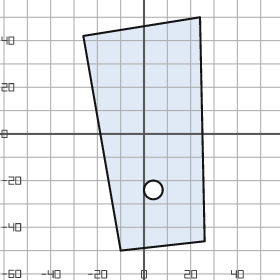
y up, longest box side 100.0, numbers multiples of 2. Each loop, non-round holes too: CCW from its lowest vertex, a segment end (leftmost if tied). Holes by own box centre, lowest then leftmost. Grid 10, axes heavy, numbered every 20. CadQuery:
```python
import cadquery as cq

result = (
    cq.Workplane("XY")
    .moveTo(-10.0, -50.0)
    .lineTo(26.0, -46.0)
    .lineTo(24.0, 50.0)
    .lineTo(-26.0, 42.0)
    .close()
    .moveTo(4.0, -24.0)
    .circle(4.0)
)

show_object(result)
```